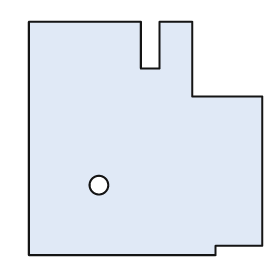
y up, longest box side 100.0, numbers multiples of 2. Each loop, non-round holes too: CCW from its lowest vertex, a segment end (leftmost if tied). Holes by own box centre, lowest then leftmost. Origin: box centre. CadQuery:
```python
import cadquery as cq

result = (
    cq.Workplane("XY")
    .moveTo(-50.0, -50.0)
    .lineTo(30.0, -50.0)
    .lineTo(30.0, -46.0)
    .lineTo(50.0, -46.0)
    .lineTo(50.0, 18.0)
    .lineTo(20.0, 18.0)
    .lineTo(20.0, 50.0)
    .lineTo(6.0, 50.0)
    .lineTo(6.0, 30.0)
    .lineTo(-2.0, 30.0)
    .lineTo(-2.0, 50.0)
    .lineTo(-50.0, 50.0)
    .close()
    .moveTo(-20.0, -20.0)
    .circle(4.0)
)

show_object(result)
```